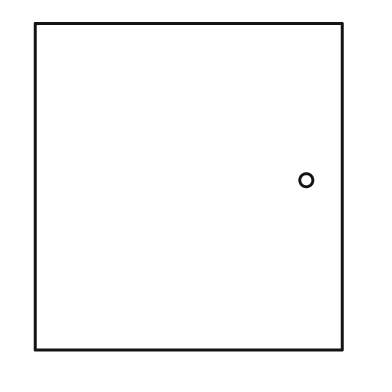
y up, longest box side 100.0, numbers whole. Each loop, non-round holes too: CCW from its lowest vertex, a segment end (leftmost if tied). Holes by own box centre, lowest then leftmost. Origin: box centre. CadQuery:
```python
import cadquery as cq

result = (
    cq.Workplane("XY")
    .moveTo(-47.0, -50.0)
    .lineTo(47.0, -50.0)
    .lineTo(47.0, 50.0)
    .lineTo(-47.0, 50.0)
    .close()
    .moveTo(36.0, 2.0)
    .circle(2.0)
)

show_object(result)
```